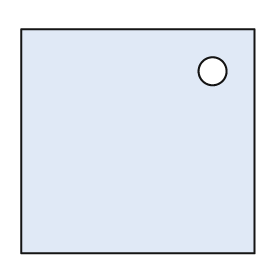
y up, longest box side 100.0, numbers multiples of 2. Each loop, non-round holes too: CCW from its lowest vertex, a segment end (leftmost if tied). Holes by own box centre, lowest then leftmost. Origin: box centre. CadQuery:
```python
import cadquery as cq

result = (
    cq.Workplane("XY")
    .moveTo(-50.0, -48.0)
    .lineTo(50.0, -48.0)
    .lineTo(50.0, 48.0)
    .lineTo(-50.0, 48.0)
    .close()
    .moveTo(32.0, 30.0)
    .circle(6.0)
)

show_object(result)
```